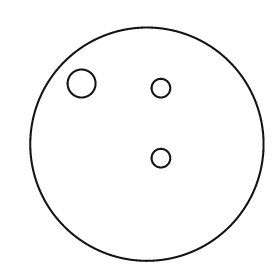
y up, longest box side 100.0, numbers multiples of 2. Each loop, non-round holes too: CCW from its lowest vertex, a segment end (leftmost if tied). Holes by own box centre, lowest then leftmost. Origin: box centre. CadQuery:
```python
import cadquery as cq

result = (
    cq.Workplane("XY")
    .moveTo(0.0, 0.0)
    .circle(50.0)
    .moveTo(6.0, -6.0)
    .circle(4.0)
    .moveTo(6.0, 24.0)
    .circle(4.0)
    .moveTo(-28.0, 26.0)
    .circle(6.0)
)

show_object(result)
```